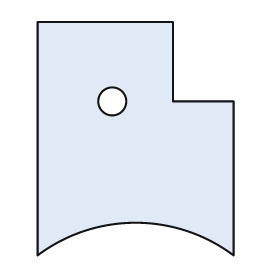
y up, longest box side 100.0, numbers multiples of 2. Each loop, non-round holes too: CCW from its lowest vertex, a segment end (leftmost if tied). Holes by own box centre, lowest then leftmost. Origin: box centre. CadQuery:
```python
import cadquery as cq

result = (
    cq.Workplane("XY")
    .moveTo(-42.0, -50.0)
    .threePointArc((0.0, -36.0), (42.0, -50.0))
    .lineTo(42.0, 16.0)
    .lineTo(16.0, 16.0)
    .lineTo(16.0, 50.0)
    .lineTo(-42.0, 50.0)
    .close()
    .moveTo(-10.0, 16.0)
    .circle(6.0)
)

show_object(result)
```